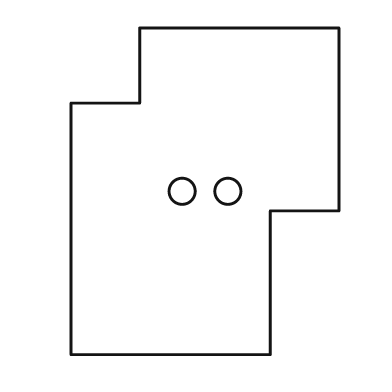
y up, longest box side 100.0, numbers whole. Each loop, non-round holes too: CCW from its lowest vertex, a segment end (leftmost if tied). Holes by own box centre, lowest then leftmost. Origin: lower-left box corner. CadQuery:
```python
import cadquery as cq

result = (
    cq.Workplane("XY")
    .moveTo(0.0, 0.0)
    .lineTo(61.0, 0.0)
    .lineTo(61.0, 44.0)
    .lineTo(82.0, 44.0)
    .lineTo(82.0, 100.0)
    .lineTo(21.0, 100.0)
    .lineTo(21.0, 77.0)
    .lineTo(0.0, 77.0)
    .close()
    .moveTo(34.0, 50.0)
    .circle(4.0)
    .moveTo(48.0, 50.0)
    .circle(4.0)
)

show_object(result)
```